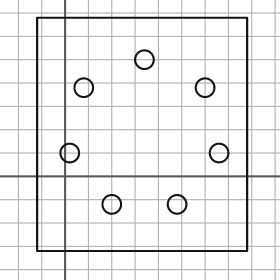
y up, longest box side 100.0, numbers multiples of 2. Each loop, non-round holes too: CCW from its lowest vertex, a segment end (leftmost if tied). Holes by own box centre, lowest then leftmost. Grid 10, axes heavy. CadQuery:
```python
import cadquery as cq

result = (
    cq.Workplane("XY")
    .moveTo(-12.0, -32.0)
    .lineTo(78.0, -32.0)
    .lineTo(78.0, 68.0)
    .lineTo(-12.0, 68.0)
    .close()
    .moveTo(20.0, -12.0)
    .circle(4.0)
    .moveTo(48.0, -12.0)
    .circle(4.0)
    .moveTo(2.0, 10.0)
    .circle(4.0)
    .moveTo(66.0, 10.0)
    .circle(4.0)
    .moveTo(8.0, 38.0)
    .circle(4.0)
    .moveTo(60.0, 38.0)
    .circle(4.0)
    .moveTo(34.0, 50.0)
    .circle(4.0)
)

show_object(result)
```